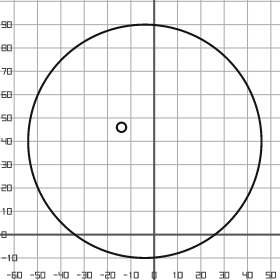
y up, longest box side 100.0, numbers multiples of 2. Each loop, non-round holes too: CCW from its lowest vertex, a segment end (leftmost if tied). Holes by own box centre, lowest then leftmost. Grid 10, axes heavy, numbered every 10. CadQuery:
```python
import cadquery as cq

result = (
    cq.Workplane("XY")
    .moveTo(-4.0, 40.0)
    .circle(50.0)
    .moveTo(-14.0, 46.0)
    .circle(2.0)
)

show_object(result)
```